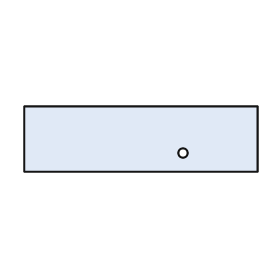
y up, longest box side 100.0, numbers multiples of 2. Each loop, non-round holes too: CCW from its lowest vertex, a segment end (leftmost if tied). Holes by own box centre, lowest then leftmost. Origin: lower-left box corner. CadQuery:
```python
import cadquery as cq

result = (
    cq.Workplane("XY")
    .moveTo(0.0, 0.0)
    .lineTo(100.0, 0.0)
    .lineTo(100.0, 28.0)
    .lineTo(0.0, 28.0)
    .close()
    .moveTo(68.0, 8.0)
    .circle(2.0)
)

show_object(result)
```